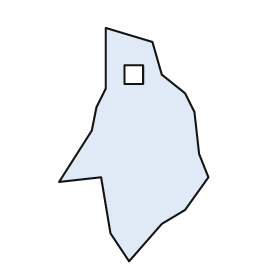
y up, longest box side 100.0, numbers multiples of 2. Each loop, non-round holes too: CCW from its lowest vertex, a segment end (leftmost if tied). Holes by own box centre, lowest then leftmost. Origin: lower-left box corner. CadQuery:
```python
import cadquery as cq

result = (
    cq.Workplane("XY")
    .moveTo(30.0, 0.0)
    .lineTo(44.0, 16.0)
    .lineTo(54.0, 22.0)
    .lineTo(64.0, 36.0)
    .lineTo(60.0, 46.0)
    .lineTo(58.0, 64.0)
    .lineTo(54.0, 72.0)
    .lineTo(44.0, 80.0)
    .lineTo(40.0, 94.0)
    .lineTo(20.0, 100.0)
    .lineTo(20.0, 74.0)
    .lineTo(16.0, 66.0)
    .lineTo(14.0, 56.0)
    .lineTo(0.0, 34.0)
    .lineTo(18.0, 36.0)
    .lineTo(22.0, 12.0)
    .close()
    .moveTo(28.0, 76.0)
    .lineTo(36.0, 76.0)
    .lineTo(36.0, 84.0)
    .lineTo(28.0, 84.0)
    .close()
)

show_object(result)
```